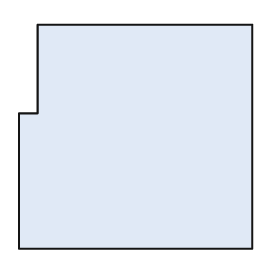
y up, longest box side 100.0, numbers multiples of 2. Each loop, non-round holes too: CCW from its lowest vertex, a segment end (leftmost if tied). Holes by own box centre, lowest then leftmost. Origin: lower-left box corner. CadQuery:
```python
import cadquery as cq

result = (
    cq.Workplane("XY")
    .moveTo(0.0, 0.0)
    .lineTo(100.0, 0.0)
    .lineTo(100.0, 96.0)
    .lineTo(8.0, 96.0)
    .lineTo(8.0, 58.0)
    .lineTo(0.0, 58.0)
    .close()
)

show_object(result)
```